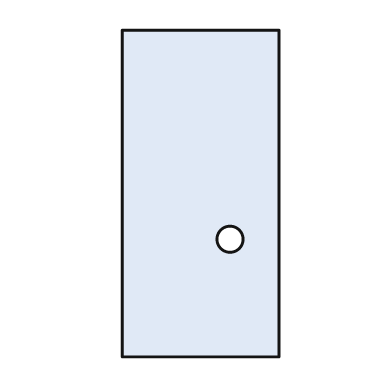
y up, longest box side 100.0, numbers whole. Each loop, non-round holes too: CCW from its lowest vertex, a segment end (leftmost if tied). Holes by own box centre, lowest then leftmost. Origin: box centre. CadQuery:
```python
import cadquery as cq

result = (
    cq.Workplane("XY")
    .moveTo(-24.0, -50.0)
    .lineTo(24.0, -50.0)
    .lineTo(24.0, 50.0)
    .lineTo(-24.0, 50.0)
    .close()
    .moveTo(9.0, -14.0)
    .circle(4.0)
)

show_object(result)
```